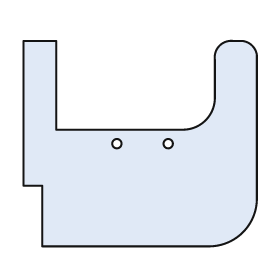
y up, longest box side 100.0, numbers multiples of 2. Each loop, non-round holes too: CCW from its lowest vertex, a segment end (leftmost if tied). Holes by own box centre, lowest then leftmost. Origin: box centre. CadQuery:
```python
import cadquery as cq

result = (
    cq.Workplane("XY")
    .moveTo(-42.0, -44.0)
    .lineTo(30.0, -44.0)
    .threePointArc((44.0, -38.0), (50.0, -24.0))
    .lineTo(50.0, 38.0)
    .threePointArc((48.0, 42.0), (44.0, 44.0))
    .lineTo(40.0, 44.0)
    .threePointArc((34.0, 42.0), (32.0, 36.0))
    .lineTo(32.0, 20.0)
    .threePointArc((28.0, 10.0), (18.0, 6.0))
    .lineTo(-36.0, 6.0)
    .lineTo(-36.0, 44.0)
    .lineTo(-50.0, 44.0)
    .lineTo(-50.0, -18.0)
    .lineTo(-42.0, -18.0)
    .close()
    .moveTo(-10.0, 0.0)
    .circle(2.0)
    .moveTo(12.0, 0.0)
    .circle(2.0)
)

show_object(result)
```